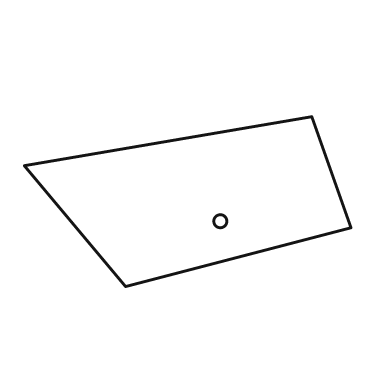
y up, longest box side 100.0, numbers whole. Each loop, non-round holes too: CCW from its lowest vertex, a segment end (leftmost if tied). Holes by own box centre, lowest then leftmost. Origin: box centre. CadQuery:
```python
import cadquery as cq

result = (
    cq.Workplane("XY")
    .moveTo(-19.0, -26.0)
    .lineTo(50.0, -8.0)
    .lineTo(38.0, 26.0)
    .lineTo(-50.0, 11.0)
    .close()
    .moveTo(10.0, -6.0)
    .circle(2.0)
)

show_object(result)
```